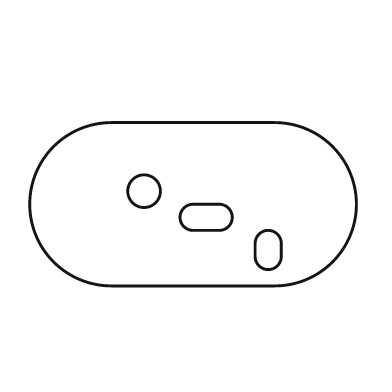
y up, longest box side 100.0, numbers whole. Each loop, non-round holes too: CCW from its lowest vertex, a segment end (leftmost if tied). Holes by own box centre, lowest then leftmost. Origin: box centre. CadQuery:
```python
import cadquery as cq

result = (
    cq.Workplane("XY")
    .moveTo(-25.0, -25.0)
    .lineTo(25.0, -25.0)
    .threePointArc((50.0, 0.0), (25.0, 25.0))
    .lineTo(-25.0, 25.0)
    .threePointArc((-50.0, 0.0), (-25.0, -25.0))
    .close()
    .moveTo(19.0, -16.0)
    .threePointArc((23.0, -20.0), (27.0, -16.0))
    .lineTo(27.0, -12.0)
    .threePointArc((23.0, -8.0), (19.0, -12.0))
    .close()
    .moveTo(0.0, -8.0)
    .lineTo(8.0, -8.0)
    .threePointArc((12.0, -4.0), (8.0, 0.0))
    .lineTo(0.0, 0.0)
    .threePointArc((-4.0, -4.0), (0.0, -8.0))
    .close()
    .moveTo(-15.0, 4.0)
    .circle(5.0)
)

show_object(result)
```